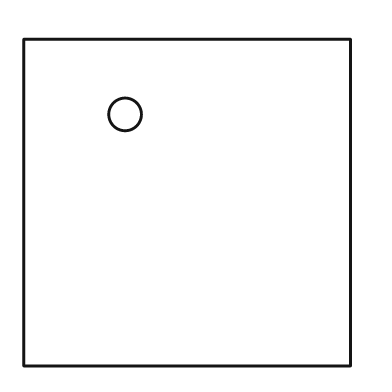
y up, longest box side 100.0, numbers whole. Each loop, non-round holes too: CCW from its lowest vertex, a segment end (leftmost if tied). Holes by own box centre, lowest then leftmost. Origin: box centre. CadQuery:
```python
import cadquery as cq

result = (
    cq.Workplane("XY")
    .moveTo(-50.0, -50.0)
    .lineTo(50.0, -50.0)
    .lineTo(50.0, 50.0)
    .lineTo(-50.0, 50.0)
    .close()
    .moveTo(-19.0, 27.0)
    .circle(5.0)
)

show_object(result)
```